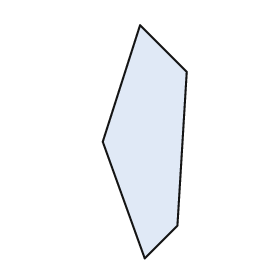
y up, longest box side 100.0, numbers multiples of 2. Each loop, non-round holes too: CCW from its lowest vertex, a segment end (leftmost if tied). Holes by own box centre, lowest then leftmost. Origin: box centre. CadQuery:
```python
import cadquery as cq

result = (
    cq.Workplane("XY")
    .moveTo(0.0, -50.0)
    .lineTo(14.0, -36.0)
    .lineTo(18.0, 30.0)
    .lineTo(-2.0, 50.0)
    .lineTo(-18.0, 0.0)
    .close()
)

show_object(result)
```